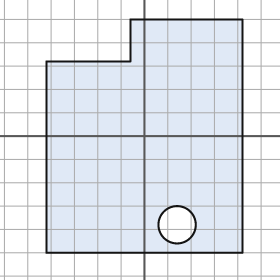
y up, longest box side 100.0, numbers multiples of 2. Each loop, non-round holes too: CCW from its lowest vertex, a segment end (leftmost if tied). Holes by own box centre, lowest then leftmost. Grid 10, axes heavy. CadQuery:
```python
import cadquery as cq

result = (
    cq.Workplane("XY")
    .moveTo(-42.0, -50.0)
    .lineTo(42.0, -50.0)
    .lineTo(42.0, 50.0)
    .lineTo(-6.0, 50.0)
    .lineTo(-6.0, 32.0)
    .lineTo(-42.0, 32.0)
    .close()
    .moveTo(14.0, -38.0)
    .circle(8.0)
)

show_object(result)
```